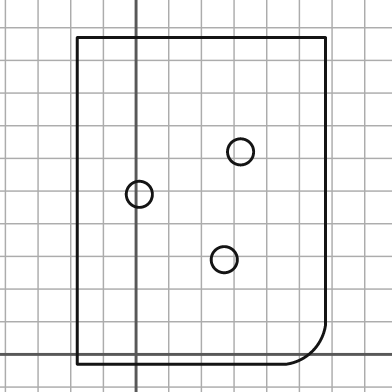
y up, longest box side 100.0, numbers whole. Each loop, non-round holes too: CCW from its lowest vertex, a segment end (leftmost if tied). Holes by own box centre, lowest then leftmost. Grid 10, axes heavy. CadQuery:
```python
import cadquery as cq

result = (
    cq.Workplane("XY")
    .moveTo(-18.0, -3.0)
    .lineTo(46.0, -3.0)
    .threePointArc((54.0, 1.0), (58.0, 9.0))
    .lineTo(58.0, 97.0)
    .lineTo(-18.0, 97.0)
    .close()
    .moveTo(27.0, 29.0)
    .circle(4.0)
    .moveTo(1.0, 49.0)
    .circle(4.0)
    .moveTo(32.0, 62.0)
    .circle(4.0)
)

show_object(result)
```